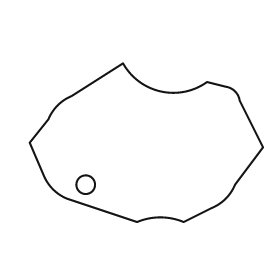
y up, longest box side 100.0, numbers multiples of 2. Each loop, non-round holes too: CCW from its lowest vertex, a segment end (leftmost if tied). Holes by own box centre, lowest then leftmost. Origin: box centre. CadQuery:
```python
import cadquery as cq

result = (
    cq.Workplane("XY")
    .moveTo(-4.0, -34.0)
    .threePointArc((6.0, -32.0), (16.0, -34.0))
    .lineTo(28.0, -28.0)
    .threePointArc((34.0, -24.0), (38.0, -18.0))
    .lineTo(50.0, -2.0)
    .lineTo(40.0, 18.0)
    .threePointArc((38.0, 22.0), (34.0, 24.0))
    .lineTo(26.0, 26.0)
    .threePointArc((6.0, 22.0), (-10.0, 34.0))
    .lineTo(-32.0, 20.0)
    .threePointArc((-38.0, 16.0), (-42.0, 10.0))
    .lineTo(-50.0, 0.0)
    .lineTo(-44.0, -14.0)
    .threePointArc((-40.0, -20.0), (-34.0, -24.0))
    .close()
    .moveTo(-26.0, -18.0)
    .circle(4.0)
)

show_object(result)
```